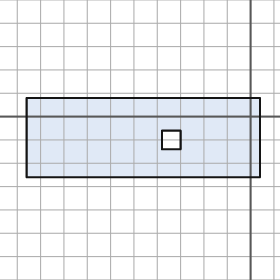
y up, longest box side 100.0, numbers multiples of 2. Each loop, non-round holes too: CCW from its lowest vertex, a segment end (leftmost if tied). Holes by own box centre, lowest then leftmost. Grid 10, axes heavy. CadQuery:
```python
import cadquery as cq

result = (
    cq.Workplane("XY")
    .moveTo(-96.0, -26.0)
    .lineTo(4.0, -26.0)
    .lineTo(4.0, 8.0)
    .lineTo(-96.0, 8.0)
    .close()
    .moveTo(-38.0, -14.0)
    .lineTo(-30.0, -14.0)
    .lineTo(-30.0, -6.0)
    .lineTo(-38.0, -6.0)
    .close()
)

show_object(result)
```